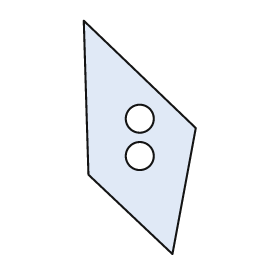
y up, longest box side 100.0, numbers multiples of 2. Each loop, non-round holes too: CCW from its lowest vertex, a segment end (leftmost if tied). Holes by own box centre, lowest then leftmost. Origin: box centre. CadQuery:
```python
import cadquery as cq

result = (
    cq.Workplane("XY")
    .moveTo(14.0, -50.0)
    .lineTo(24.0, 4.0)
    .lineTo(-24.0, 50.0)
    .lineTo(-22.0, -16.0)
    .close()
    .moveTo(0.0, -8.0)
    .circle(6.0)
    .moveTo(0.0, 8.0)
    .circle(6.0)
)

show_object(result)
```